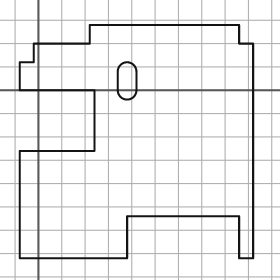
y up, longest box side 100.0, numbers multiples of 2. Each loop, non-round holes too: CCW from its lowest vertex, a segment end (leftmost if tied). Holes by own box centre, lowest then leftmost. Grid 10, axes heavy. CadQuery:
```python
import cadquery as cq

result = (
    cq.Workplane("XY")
    .moveTo(-8.0, -72.0)
    .lineTo(38.0, -72.0)
    .lineTo(38.0, -54.0)
    .lineTo(86.0, -54.0)
    .lineTo(86.0, -72.0)
    .lineTo(92.0, -72.0)
    .lineTo(92.0, 20.0)
    .lineTo(86.0, 20.0)
    .lineTo(86.0, 28.0)
    .lineTo(22.0, 28.0)
    .lineTo(22.0, 20.0)
    .lineTo(-2.0, 20.0)
    .lineTo(-2.0, 12.0)
    .lineTo(-8.0, 12.0)
    .lineTo(-8.0, 0.0)
    .lineTo(24.0, 0.0)
    .lineTo(24.0, -26.0)
    .lineTo(-8.0, -26.0)
    .close()
    .moveTo(34.0, 0.0)
    .threePointArc((38.0, -4.0), (42.0, 0.0))
    .lineTo(42.0, 8.0)
    .threePointArc((38.0, 12.0), (34.0, 8.0))
    .close()
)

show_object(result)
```